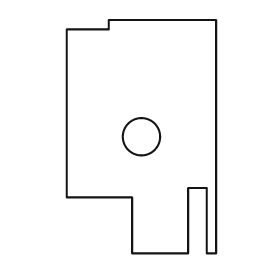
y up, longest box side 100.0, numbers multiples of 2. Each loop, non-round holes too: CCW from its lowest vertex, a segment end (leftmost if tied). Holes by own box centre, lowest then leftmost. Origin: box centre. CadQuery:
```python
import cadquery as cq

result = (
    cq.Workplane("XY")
    .moveTo(-4.0, -50.0)
    .lineTo(20.0, -50.0)
    .lineTo(20.0, -22.0)
    .lineTo(28.0, -22.0)
    .lineTo(28.0, -50.0)
    .lineTo(32.0, -50.0)
    .lineTo(32.0, 50.0)
    .lineTo(-14.0, 50.0)
    .lineTo(-14.0, 46.0)
    .lineTo(-32.0, 46.0)
    .lineTo(-32.0, -26.0)
    .lineTo(-4.0, -26.0)
    .close()
    .moveTo(0.0, 0.0)
    .circle(8.0)
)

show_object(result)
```